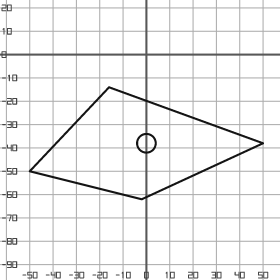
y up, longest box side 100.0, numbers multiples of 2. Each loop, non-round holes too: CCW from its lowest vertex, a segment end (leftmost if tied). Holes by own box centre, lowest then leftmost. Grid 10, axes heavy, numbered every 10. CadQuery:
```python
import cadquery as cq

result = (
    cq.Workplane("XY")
    .moveTo(-2.0, -62.0)
    .lineTo(50.0, -38.0)
    .lineTo(-16.0, -14.0)
    .lineTo(-50.0, -50.0)
    .close()
    .moveTo(0.0, -38.0)
    .circle(4.0)
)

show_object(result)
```